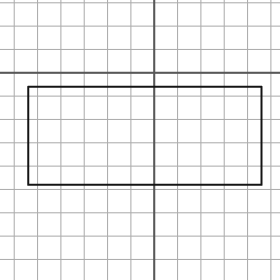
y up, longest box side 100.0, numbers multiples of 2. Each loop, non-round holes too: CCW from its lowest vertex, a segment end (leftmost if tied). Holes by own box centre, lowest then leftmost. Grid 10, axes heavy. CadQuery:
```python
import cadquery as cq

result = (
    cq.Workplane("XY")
    .moveTo(-54.0, -48.0)
    .lineTo(46.0, -48.0)
    .lineTo(46.0, -6.0)
    .lineTo(-54.0, -6.0)
    .close()
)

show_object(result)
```